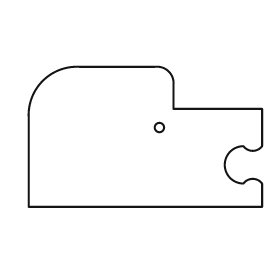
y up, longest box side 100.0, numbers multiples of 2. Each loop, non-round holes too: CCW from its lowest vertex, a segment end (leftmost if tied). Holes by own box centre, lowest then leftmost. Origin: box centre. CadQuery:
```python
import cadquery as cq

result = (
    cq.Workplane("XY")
    .moveTo(-50.0, -30.0)
    .lineTo(50.0, -30.0)
    .lineTo(50.0, -20.0)
    .threePointArc((46.0, -18.0), (42.0, -20.0))
    .threePointArc((34.0, -12.0), (42.0, -4.0))
    .threePointArc((46.0, -6.0), (50.0, -4.0))
    .lineTo(50.0, 12.0)
    .lineTo(12.0, 12.0)
    .lineTo(12.0, 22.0)
    .threePointArc((10.0, 28.0), (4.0, 30.0))
    .lineTo(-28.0, 30.0)
    .threePointArc((-44.0, 24.0), (-50.0, 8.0))
    .close()
    .moveTo(6.0, 4.0)
    .circle(2.0)
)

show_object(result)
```